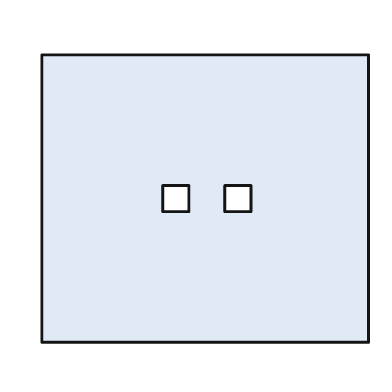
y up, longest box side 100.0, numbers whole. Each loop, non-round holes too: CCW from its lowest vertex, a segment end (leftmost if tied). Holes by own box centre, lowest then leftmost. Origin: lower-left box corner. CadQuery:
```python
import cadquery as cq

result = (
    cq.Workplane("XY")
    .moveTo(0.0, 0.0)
    .lineTo(100.0, 0.0)
    .lineTo(100.0, 88.0)
    .lineTo(0.0, 88.0)
    .close()
    .moveTo(37.0, 40.0)
    .lineTo(45.0, 40.0)
    .lineTo(45.0, 48.0)
    .lineTo(37.0, 48.0)
    .close()
    .moveTo(56.0, 40.0)
    .lineTo(64.0, 40.0)
    .lineTo(64.0, 48.0)
    .lineTo(56.0, 48.0)
    .close()
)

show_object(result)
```